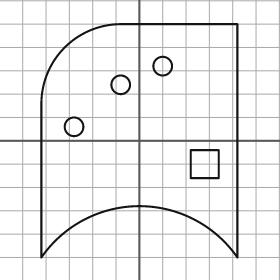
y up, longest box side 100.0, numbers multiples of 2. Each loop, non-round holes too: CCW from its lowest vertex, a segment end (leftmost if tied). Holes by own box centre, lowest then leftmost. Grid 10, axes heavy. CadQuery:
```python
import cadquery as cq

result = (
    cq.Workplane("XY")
    .moveTo(-42.0, -50.0)
    .threePointArc((0.0, -28.0), (42.0, -50.0))
    .lineTo(42.0, 50.0)
    .lineTo(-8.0, 50.0)
    .threePointArc((-32.0, 40.0), (-42.0, 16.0))
    .close()
    .moveTo(22.0, -16.0)
    .lineTo(34.0, -16.0)
    .lineTo(34.0, -4.0)
    .lineTo(22.0, -4.0)
    .close()
    .moveTo(-28.0, 6.0)
    .circle(4.0)
    .moveTo(-8.0, 24.0)
    .circle(4.0)
    .moveTo(10.0, 32.0)
    .circle(4.0)
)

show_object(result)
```